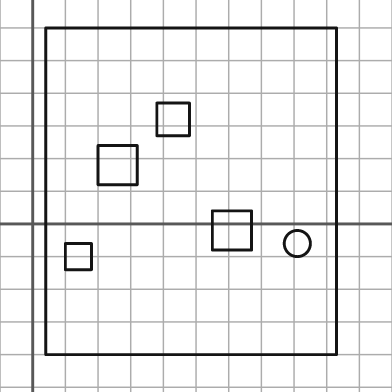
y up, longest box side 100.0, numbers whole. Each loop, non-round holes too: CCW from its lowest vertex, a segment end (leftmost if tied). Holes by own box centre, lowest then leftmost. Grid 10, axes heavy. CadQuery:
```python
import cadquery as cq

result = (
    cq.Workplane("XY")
    .moveTo(4.0, -40.0)
    .lineTo(93.0, -40.0)
    .lineTo(93.0, 60.0)
    .lineTo(4.0, 60.0)
    .close()
    .moveTo(10.0, -14.0)
    .lineTo(18.0, -14.0)
    .lineTo(18.0, -6.0)
    .lineTo(10.0, -6.0)
    .close()
    .moveTo(81.0, -6.0)
    .circle(4.0)
    .moveTo(55.0, -8.0)
    .lineTo(67.0, -8.0)
    .lineTo(67.0, 4.0)
    .lineTo(55.0, 4.0)
    .close()
    .moveTo(20.0, 12.0)
    .lineTo(32.0, 12.0)
    .lineTo(32.0, 24.0)
    .lineTo(20.0, 24.0)
    .close()
    .moveTo(38.0, 27.0)
    .lineTo(48.0, 27.0)
    .lineTo(48.0, 37.0)
    .lineTo(38.0, 37.0)
    .close()
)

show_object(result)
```